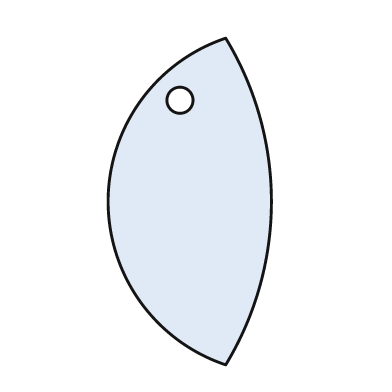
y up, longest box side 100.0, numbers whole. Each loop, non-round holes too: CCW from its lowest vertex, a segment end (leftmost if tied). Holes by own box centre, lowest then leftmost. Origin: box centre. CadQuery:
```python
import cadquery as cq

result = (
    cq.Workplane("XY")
    .moveTo(11.0, -50.0)
    .threePointArc((25.0, 0.0), (11.0, 50.0))
    .threePointArc((-25.0, 0.0), (11.0, -50.0))
    .close()
    .moveTo(-3.0, 31.0)
    .circle(4.0)
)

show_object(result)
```